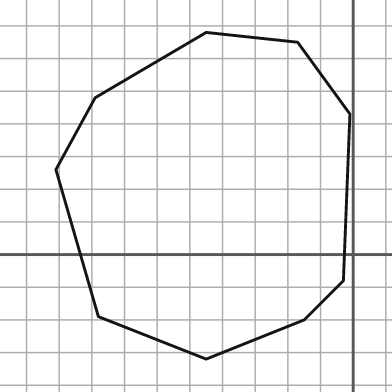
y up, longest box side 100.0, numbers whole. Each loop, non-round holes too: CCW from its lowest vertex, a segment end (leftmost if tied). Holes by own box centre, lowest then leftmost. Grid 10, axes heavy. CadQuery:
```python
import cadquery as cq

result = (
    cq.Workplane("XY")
    .moveTo(-45.0, -32.0)
    .lineTo(-15.0, -20.0)
    .lineTo(-3.0, -8.0)
    .lineTo(-1.0, 43.0)
    .lineTo(-17.0, 65.0)
    .lineTo(-45.0, 68.0)
    .lineTo(-79.0, 48.0)
    .lineTo(-91.0, 26.0)
    .lineTo(-78.0, -19.0)
    .close()
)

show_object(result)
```